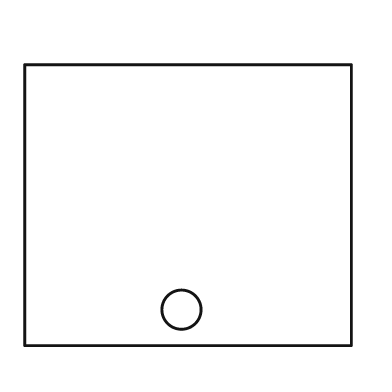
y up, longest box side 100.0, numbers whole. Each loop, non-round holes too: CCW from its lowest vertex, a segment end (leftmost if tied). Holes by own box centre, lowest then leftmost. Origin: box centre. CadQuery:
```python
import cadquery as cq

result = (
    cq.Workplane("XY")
    .moveTo(-50.0, -43.0)
    .lineTo(50.0, -43.0)
    .lineTo(50.0, 43.0)
    .lineTo(-50.0, 43.0)
    .close()
    .moveTo(-2.0, -32.0)
    .circle(6.0)
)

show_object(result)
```